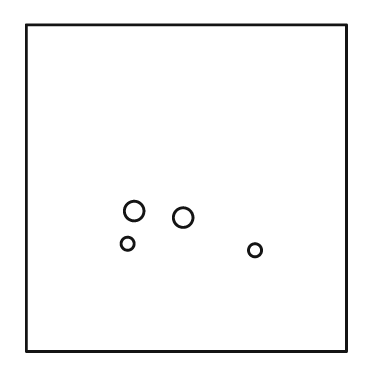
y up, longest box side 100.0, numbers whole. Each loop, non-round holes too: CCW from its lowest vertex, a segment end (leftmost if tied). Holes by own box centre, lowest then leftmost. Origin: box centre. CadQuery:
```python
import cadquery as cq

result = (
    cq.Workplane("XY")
    .moveTo(-49.0, -50.0)
    .lineTo(49.0, -50.0)
    .lineTo(49.0, 50.0)
    .lineTo(-49.0, 50.0)
    .close()
    .moveTo(21.0, -19.0)
    .circle(2.0)
    .moveTo(-18.0, -17.0)
    .circle(2.0)
    .moveTo(-1.0, -9.0)
    .circle(3.0)
    .moveTo(-16.0, -7.0)
    .circle(3.0)
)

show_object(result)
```